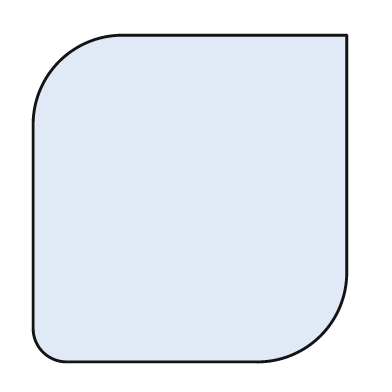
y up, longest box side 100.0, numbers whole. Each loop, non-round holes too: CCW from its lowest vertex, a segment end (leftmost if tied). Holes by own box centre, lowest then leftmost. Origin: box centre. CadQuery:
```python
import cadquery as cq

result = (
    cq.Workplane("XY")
    .moveTo(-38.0, -50.0)
    .lineTo(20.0, -50.0)
    .threePointArc((40.0, -42.0), (48.0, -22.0))
    .lineTo(48.0, 50.0)
    .lineTo(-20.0, 50.0)
    .threePointArc((-40.0, 42.0), (-48.0, 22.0))
    .lineTo(-48.0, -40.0)
    .threePointArc((-45.0, -47.0), (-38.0, -50.0))
    .close()
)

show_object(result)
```